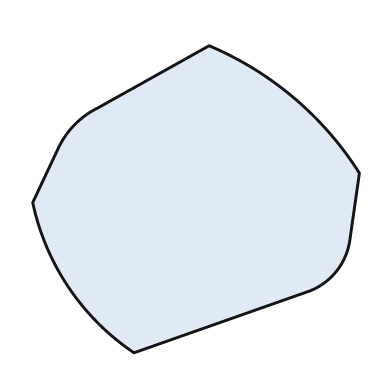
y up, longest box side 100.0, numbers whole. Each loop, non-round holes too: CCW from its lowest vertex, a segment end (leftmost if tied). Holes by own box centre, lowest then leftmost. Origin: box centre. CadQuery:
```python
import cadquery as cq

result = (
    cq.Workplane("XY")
    .moveTo(-19.0, -47.0)
    .lineTo(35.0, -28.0)
    .threePointArc((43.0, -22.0), (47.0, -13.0))
    .lineTo(50.0, 8.0)
    .threePointArc((30.0, 31.0), (4.0, 47.0))
    .lineTo(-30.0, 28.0)
    .threePointArc((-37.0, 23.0), (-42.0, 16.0))
    .lineTo(-50.0, -1.0)
    .threePointArc((-39.0, -27.0), (-19.0, -47.0))
    .close()
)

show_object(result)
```